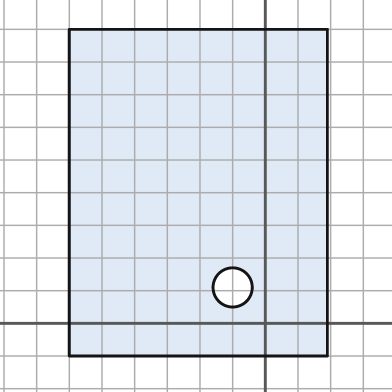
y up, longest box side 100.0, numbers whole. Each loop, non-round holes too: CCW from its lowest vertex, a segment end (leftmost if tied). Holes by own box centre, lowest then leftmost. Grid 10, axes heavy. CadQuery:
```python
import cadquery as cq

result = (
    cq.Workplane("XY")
    .moveTo(-60.0, -10.0)
    .lineTo(19.0, -10.0)
    .lineTo(19.0, 90.0)
    .lineTo(-60.0, 90.0)
    .close()
    .moveTo(-10.0, 11.0)
    .circle(6.0)
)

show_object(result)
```